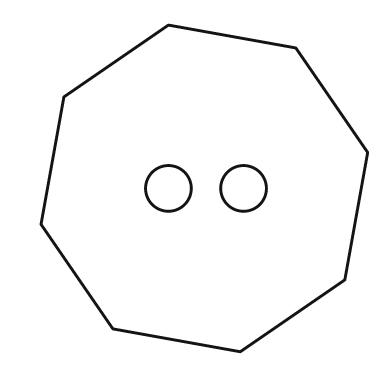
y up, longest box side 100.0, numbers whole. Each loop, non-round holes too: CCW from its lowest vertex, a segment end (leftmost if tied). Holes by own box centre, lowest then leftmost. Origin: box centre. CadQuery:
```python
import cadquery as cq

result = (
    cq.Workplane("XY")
    .moveTo(11.0, -50.0)
    .lineTo(43.0, -28.0)
    .lineTo(50.0, 11.0)
    .lineTo(28.0, 43.0)
    .lineTo(-11.0, 50.0)
    .lineTo(-43.0, 28.0)
    .lineTo(-50.0, -11.0)
    .lineTo(-28.0, -43.0)
    .close()
    .moveTo(-11.0, 0.0)
    .circle(7.0)
    .moveTo(12.0, 0.0)
    .circle(7.0)
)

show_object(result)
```